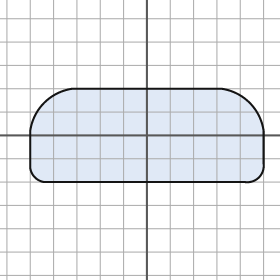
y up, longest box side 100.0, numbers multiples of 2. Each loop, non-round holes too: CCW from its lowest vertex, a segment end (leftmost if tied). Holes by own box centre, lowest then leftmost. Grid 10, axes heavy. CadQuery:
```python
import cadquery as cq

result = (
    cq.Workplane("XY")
    .moveTo(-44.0, -20.0)
    .lineTo(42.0, -20.0)
    .threePointArc((48.0, -18.0), (50.0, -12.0))
    .lineTo(50.0, 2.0)
    .threePointArc((44.0, 14.0), (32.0, 20.0))
    .lineTo(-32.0, 20.0)
    .threePointArc((-44.0, 14.0), (-50.0, 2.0))
    .lineTo(-50.0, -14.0)
    .threePointArc((-48.0, -18.0), (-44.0, -20.0))
    .close()
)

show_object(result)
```